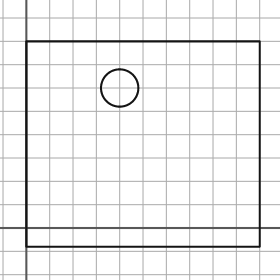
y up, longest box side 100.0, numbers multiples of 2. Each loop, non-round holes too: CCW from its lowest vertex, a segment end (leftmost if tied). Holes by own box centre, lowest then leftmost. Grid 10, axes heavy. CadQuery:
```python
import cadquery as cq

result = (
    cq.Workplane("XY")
    .moveTo(0.0, -8.0)
    .lineTo(100.0, -8.0)
    .lineTo(100.0, 80.0)
    .lineTo(0.0, 80.0)
    .close()
    .moveTo(40.0, 60.0)
    .circle(8.0)
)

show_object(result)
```